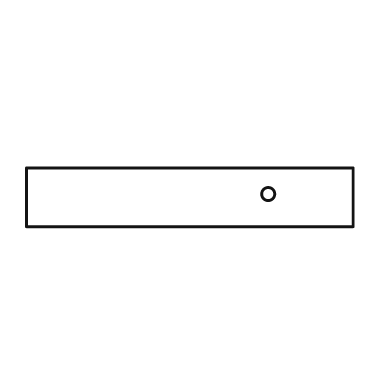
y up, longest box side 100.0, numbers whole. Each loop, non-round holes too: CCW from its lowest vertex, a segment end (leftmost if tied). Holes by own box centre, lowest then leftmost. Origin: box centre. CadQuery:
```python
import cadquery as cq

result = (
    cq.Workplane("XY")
    .moveTo(-50.0, -9.0)
    .lineTo(50.0, -9.0)
    .lineTo(50.0, 9.0)
    .lineTo(-50.0, 9.0)
    .close()
    .moveTo(24.0, 1.0)
    .circle(2.0)
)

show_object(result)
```